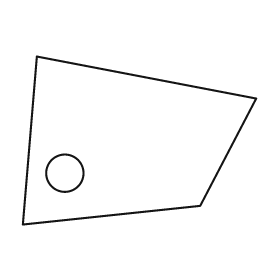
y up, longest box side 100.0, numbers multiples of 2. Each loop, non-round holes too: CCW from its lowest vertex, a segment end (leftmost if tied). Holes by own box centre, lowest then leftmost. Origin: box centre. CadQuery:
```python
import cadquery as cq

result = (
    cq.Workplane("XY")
    .moveTo(-50.0, -36.0)
    .lineTo(26.0, -28.0)
    .lineTo(50.0, 18.0)
    .lineTo(-44.0, 36.0)
    .close()
    .moveTo(-32.0, -14.0)
    .circle(8.0)
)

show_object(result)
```